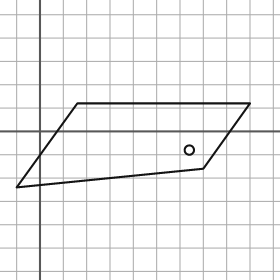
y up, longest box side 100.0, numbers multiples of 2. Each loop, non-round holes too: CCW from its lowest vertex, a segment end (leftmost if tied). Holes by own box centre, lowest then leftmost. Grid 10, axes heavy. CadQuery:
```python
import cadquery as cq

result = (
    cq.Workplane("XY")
    .moveTo(-10.0, -24.0)
    .lineTo(70.0, -16.0)
    .lineTo(90.0, 12.0)
    .lineTo(16.0, 12.0)
    .close()
    .moveTo(64.0, -8.0)
    .circle(2.0)
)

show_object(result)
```